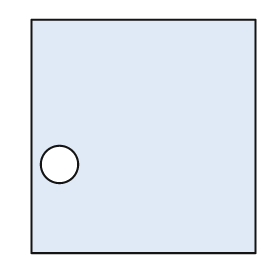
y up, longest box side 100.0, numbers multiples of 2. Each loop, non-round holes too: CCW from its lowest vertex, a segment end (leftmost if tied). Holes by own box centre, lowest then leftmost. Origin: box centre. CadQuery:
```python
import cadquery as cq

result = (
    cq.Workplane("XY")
    .moveTo(-48.0, -50.0)
    .lineTo(48.0, -50.0)
    .lineTo(48.0, 50.0)
    .lineTo(-48.0, 50.0)
    .close()
    .moveTo(-36.0, -12.0)
    .circle(8.0)
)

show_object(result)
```